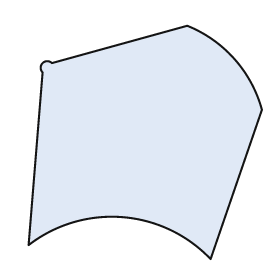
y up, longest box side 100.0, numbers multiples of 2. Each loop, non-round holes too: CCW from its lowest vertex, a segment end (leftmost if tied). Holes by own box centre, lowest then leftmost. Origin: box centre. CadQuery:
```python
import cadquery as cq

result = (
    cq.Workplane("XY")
    .moveTo(28.0, -50.0)
    .lineTo(50.0, 14.0)
    .threePointArc((38.0, 36.0), (18.0, 50.0))
    .lineTo(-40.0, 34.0)
    .threePointArc((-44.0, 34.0), (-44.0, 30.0))
    .lineTo(-50.0, -44.0)
    .threePointArc((-10.0, -32.0), (28.0, -50.0))
    .close()
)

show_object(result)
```